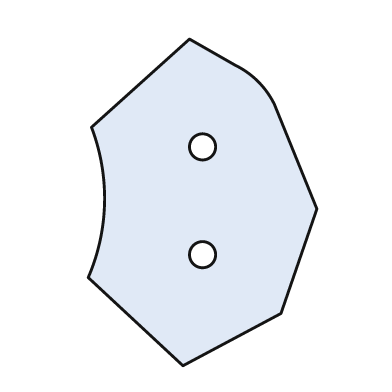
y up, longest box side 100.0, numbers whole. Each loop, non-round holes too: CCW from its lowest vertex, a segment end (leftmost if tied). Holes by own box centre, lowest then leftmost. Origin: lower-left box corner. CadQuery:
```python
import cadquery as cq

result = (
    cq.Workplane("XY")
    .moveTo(29.0, 0.0)
    .lineTo(59.0, 16.0)
    .lineTo(70.0, 48.0)
    .lineTo(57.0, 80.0)
    .threePointArc((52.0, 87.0), (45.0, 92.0))
    .lineTo(31.0, 100.0)
    .lineTo(1.0, 73.0)
    .threePointArc((5.0, 50.0), (0.0, 27.0))
    .close()
    .moveTo(35.0, 34.0)
    .circle(4.0)
    .moveTo(35.0, 67.0)
    .circle(4.0)
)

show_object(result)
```